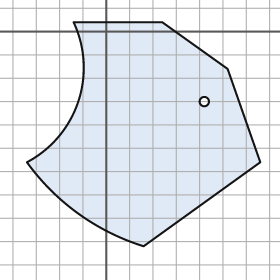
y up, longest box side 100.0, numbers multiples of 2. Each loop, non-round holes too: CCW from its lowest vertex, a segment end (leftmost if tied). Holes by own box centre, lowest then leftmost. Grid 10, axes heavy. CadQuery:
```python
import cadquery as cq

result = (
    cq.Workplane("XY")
    .moveTo(16.0, -92.0)
    .lineTo(66.0, -56.0)
    .lineTo(52.0, -16.0)
    .lineTo(24.0, 4.0)
    .lineTo(-14.0, 4.0)
    .threePointArc((-12.0, -30.0), (-34.0, -56.0))
    .threePointArc((-12.0, -78.0), (16.0, -92.0))
    .close()
    .moveTo(42.0, -30.0)
    .circle(2.0)
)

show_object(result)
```